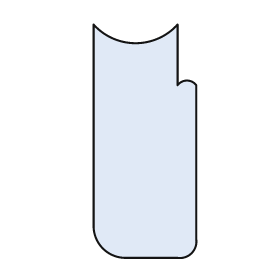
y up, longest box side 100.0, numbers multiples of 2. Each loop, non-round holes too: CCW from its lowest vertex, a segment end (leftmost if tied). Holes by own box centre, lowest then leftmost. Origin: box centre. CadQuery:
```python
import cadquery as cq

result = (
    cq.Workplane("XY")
    .moveTo(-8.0, -50.0)
    .lineTo(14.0, -50.0)
    .threePointArc((20.0, -48.0), (22.0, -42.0))
    .lineTo(22.0, 24.0)
    .threePointArc((18.0, 26.0), (14.0, 24.0))
    .lineTo(14.0, 50.0)
    .threePointArc((-4.0, 42.0), (-22.0, 50.0))
    .lineTo(-22.0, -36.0)
    .threePointArc((-18.0, -46.0), (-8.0, -50.0))
    .close()
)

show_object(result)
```